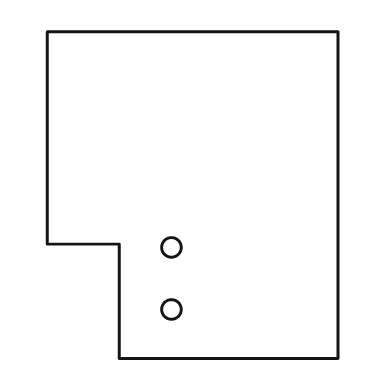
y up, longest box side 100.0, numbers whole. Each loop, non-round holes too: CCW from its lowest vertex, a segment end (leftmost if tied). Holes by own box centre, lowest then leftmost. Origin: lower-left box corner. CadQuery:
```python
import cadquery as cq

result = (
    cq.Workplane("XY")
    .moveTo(22.0, 0.0)
    .lineTo(89.0, 0.0)
    .lineTo(89.0, 100.0)
    .lineTo(0.0, 100.0)
    .lineTo(0.0, 35.0)
    .lineTo(22.0, 35.0)
    .close()
    .moveTo(38.0, 15.0)
    .circle(3.0)
    .moveTo(38.0, 34.0)
    .circle(3.0)
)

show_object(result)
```